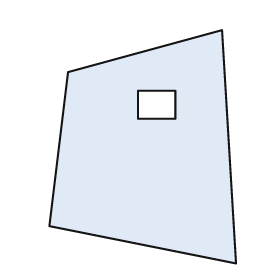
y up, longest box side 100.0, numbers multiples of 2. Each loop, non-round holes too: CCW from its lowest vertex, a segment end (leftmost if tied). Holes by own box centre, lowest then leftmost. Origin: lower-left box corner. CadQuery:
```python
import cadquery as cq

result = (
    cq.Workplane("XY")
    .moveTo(80.0, 0.0)
    .lineTo(74.0, 100.0)
    .lineTo(8.0, 82.0)
    .lineTo(0.0, 16.0)
    .close()
    .moveTo(38.0, 62.0)
    .lineTo(54.0, 62.0)
    .lineTo(54.0, 74.0)
    .lineTo(38.0, 74.0)
    .close()
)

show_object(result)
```